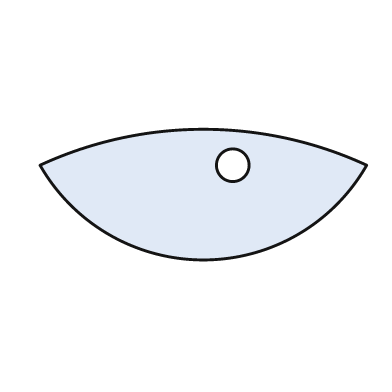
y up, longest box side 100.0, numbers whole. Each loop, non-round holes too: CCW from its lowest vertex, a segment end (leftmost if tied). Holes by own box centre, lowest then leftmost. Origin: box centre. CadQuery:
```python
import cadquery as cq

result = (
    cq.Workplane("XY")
    .moveTo(-50.0, 9.0)
    .threePointArc((0.0, -20.0), (50.0, 9.0))
    .threePointArc((0.0, 20.0), (-50.0, 9.0))
    .close()
    .moveTo(9.0, 9.0)
    .circle(5.0)
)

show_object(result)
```